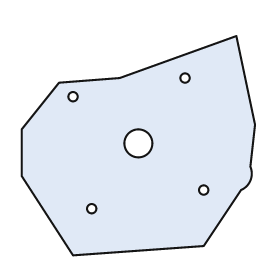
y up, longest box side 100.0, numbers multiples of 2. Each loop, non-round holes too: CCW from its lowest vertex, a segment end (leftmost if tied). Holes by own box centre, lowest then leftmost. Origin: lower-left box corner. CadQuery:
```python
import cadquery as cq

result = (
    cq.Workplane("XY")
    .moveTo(22.0, 0.0)
    .lineTo(78.0, 4.0)
    .lineTo(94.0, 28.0)
    .threePointArc((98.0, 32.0), (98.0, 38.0))
    .lineTo(100.0, 56.0)
    .lineTo(92.0, 94.0)
    .lineTo(42.0, 76.0)
    .lineTo(16.0, 74.0)
    .lineTo(0.0, 54.0)
    .lineTo(0.0, 34.0)
    .close()
    .moveTo(30.0, 20.0)
    .circle(2.0)
    .moveTo(78.0, 28.0)
    .circle(2.0)
    .moveTo(50.0, 48.0)
    .circle(6.0)
    .moveTo(22.0, 68.0)
    .circle(2.0)
    .moveTo(70.0, 76.0)
    .circle(2.0)
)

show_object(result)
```